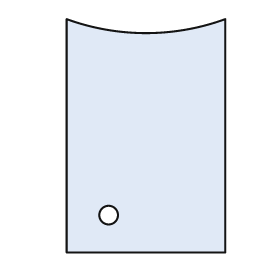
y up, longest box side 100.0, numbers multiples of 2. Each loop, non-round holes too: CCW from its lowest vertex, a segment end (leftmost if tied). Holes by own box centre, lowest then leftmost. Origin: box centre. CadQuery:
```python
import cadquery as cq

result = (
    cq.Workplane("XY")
    .moveTo(-34.0, -50.0)
    .lineTo(34.0, -50.0)
    .lineTo(34.0, 50.0)
    .threePointArc((0.0, 44.0), (-34.0, 50.0))
    .close()
    .moveTo(-16.0, -34.0)
    .circle(4.0)
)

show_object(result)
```